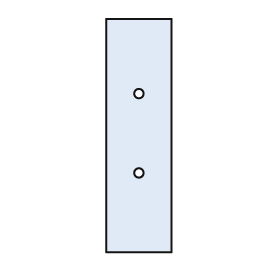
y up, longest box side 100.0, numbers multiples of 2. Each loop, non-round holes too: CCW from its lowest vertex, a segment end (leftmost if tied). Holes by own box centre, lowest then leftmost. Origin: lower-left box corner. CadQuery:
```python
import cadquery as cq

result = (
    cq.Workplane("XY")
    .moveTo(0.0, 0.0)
    .lineTo(28.0, 0.0)
    .lineTo(28.0, 100.0)
    .lineTo(0.0, 100.0)
    .close()
    .moveTo(14.0, 34.0)
    .circle(2.0)
    .moveTo(14.0, 68.0)
    .circle(2.0)
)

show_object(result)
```